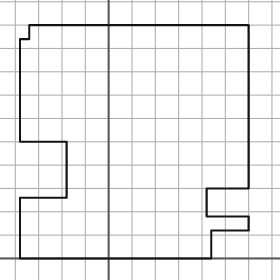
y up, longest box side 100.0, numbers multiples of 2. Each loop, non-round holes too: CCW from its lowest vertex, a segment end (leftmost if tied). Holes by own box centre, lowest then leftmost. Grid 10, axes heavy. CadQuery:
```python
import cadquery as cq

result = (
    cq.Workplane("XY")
    .moveTo(-38.0, 0.0)
    .lineTo(44.0, 0.0)
    .lineTo(44.0, 12.0)
    .lineTo(60.0, 12.0)
    .lineTo(60.0, 18.0)
    .lineTo(42.0, 18.0)
    .lineTo(42.0, 30.0)
    .lineTo(60.0, 30.0)
    .lineTo(60.0, 100.0)
    .lineTo(-34.0, 100.0)
    .lineTo(-34.0, 94.0)
    .lineTo(-38.0, 94.0)
    .lineTo(-38.0, 50.0)
    .lineTo(-18.0, 50.0)
    .lineTo(-18.0, 26.0)
    .lineTo(-38.0, 26.0)
    .close()
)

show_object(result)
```